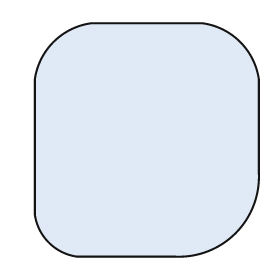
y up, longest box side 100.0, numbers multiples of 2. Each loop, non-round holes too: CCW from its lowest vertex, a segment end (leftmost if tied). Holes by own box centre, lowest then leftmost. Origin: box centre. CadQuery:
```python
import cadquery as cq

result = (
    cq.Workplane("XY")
    .moveTo(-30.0, -50.0)
    .lineTo(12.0, -50.0)
    .threePointArc((38.0, -40.0), (48.0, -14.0))
    .lineTo(48.0, 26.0)
    .threePointArc((40.0, 42.0), (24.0, 50.0))
    .lineTo(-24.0, 50.0)
    .threePointArc((-40.0, 42.0), (-48.0, 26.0))
    .lineTo(-48.0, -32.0)
    .threePointArc((-42.0, -44.0), (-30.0, -50.0))
    .close()
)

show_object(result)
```